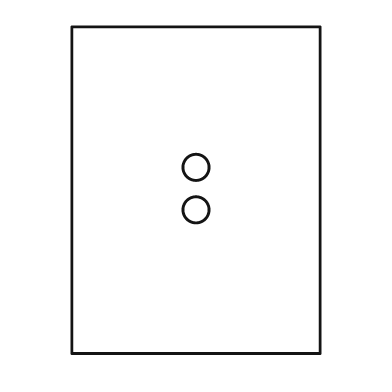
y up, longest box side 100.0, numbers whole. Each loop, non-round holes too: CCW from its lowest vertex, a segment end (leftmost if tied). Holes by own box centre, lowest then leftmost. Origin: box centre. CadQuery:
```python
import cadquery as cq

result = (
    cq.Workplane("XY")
    .moveTo(-38.0, -50.0)
    .lineTo(38.0, -50.0)
    .lineTo(38.0, 50.0)
    .lineTo(-38.0, 50.0)
    .close()
    .moveTo(0.0, -6.0)
    .circle(4.0)
    .moveTo(0.0, 7.0)
    .circle(4.0)
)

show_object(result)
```